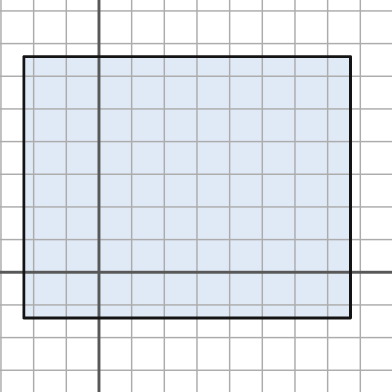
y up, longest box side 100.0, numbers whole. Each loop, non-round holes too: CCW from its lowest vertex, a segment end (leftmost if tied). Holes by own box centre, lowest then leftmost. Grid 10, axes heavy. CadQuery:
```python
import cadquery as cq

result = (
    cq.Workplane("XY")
    .moveTo(-23.0, -14.0)
    .lineTo(77.0, -14.0)
    .lineTo(77.0, 66.0)
    .lineTo(-23.0, 66.0)
    .close()
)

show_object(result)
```